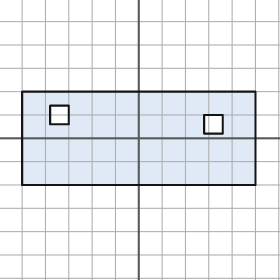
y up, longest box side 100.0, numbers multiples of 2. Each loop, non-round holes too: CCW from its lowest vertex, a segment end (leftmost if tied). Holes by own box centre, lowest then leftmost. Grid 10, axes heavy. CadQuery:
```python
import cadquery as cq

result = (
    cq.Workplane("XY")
    .moveTo(-50.0, -20.0)
    .lineTo(50.0, -20.0)
    .lineTo(50.0, 20.0)
    .lineTo(-50.0, 20.0)
    .close()
    .moveTo(28.0, 2.0)
    .lineTo(36.0, 2.0)
    .lineTo(36.0, 10.0)
    .lineTo(28.0, 10.0)
    .close()
    .moveTo(-38.0, 6.0)
    .lineTo(-30.0, 6.0)
    .lineTo(-30.0, 14.0)
    .lineTo(-38.0, 14.0)
    .close()
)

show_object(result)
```